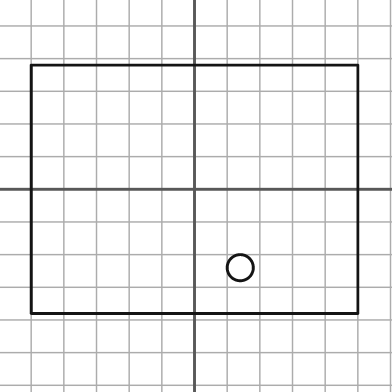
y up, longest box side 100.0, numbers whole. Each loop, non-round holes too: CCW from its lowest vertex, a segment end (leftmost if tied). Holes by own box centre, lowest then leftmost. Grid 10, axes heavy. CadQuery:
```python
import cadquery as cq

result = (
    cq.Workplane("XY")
    .moveTo(-50.0, -38.0)
    .lineTo(50.0, -38.0)
    .lineTo(50.0, 38.0)
    .lineTo(-50.0, 38.0)
    .close()
    .moveTo(14.0, -24.0)
    .circle(4.0)
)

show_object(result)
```